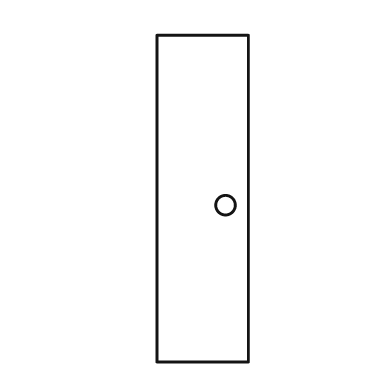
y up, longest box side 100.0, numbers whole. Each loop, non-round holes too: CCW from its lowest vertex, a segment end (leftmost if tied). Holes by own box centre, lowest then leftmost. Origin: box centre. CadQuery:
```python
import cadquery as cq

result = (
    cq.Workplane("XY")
    .moveTo(-14.0, -50.0)
    .lineTo(14.0, -50.0)
    .lineTo(14.0, 50.0)
    .lineTo(-14.0, 50.0)
    .close()
    .moveTo(7.0, -2.0)
    .circle(3.0)
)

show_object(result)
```